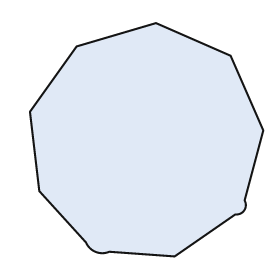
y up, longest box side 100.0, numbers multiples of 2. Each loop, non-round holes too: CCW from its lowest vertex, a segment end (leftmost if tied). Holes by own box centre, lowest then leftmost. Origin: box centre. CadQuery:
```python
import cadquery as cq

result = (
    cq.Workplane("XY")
    .moveTo(12.0, -50.0)
    .lineTo(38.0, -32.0)
    .threePointArc((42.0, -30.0), (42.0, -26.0))
    .lineTo(50.0, 4.0)
    .lineTo(36.0, 36.0)
    .lineTo(4.0, 50.0)
    .lineTo(-30.0, 40.0)
    .lineTo(-50.0, 12.0)
    .lineTo(-46.0, -22.0)
    .lineTo(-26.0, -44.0)
    .threePointArc((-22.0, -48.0), (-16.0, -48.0))
    .close()
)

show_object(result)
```